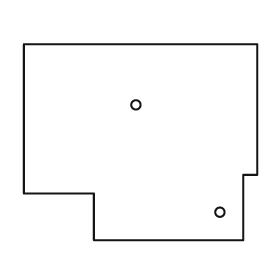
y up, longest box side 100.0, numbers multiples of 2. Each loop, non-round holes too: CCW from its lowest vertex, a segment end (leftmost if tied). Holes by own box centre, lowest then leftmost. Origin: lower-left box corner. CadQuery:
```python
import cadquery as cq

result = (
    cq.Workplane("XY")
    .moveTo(30.0, 0.0)
    .lineTo(94.0, 0.0)
    .lineTo(94.0, 28.0)
    .lineTo(100.0, 28.0)
    .lineTo(100.0, 84.0)
    .lineTo(0.0, 84.0)
    .lineTo(0.0, 20.0)
    .lineTo(30.0, 20.0)
    .close()
    .moveTo(84.0, 12.0)
    .circle(2.0)
    .moveTo(48.0, 58.0)
    .circle(2.0)
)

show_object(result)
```